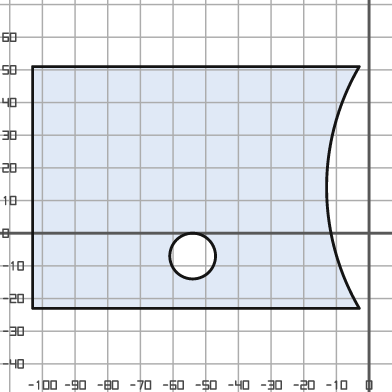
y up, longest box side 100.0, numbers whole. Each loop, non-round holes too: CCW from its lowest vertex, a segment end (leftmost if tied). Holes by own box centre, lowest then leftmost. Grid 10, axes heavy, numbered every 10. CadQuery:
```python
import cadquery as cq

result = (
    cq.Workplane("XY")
    .moveTo(-103.0, -23.0)
    .lineTo(-3.0, -23.0)
    .threePointArc((-13.0, 14.0), (-3.0, 51.0))
    .lineTo(-103.0, 51.0)
    .close()
    .moveTo(-54.0, -7.0)
    .circle(7.0)
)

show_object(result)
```